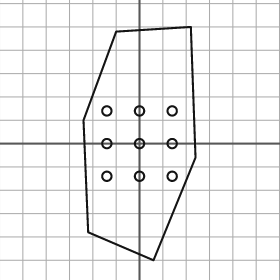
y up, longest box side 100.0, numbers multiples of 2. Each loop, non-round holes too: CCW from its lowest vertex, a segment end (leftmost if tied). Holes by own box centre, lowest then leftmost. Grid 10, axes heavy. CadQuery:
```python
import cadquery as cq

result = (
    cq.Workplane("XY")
    .moveTo(6.0, -50.0)
    .lineTo(24.0, -6.0)
    .lineTo(22.0, 50.0)
    .lineTo(-10.0, 48.0)
    .lineTo(-24.0, 10.0)
    .lineTo(-22.0, -38.0)
    .close()
    .moveTo(-14.0, -14.0)
    .circle(2.0)
    .moveTo(0.0, -14.0)
    .circle(2.0)
    .moveTo(14.0, -14.0)
    .circle(2.0)
    .moveTo(-14.0, 0.0)
    .circle(2.0)
    .moveTo(0.0, 0.0)
    .circle(2.0)
    .moveTo(14.0, 0.0)
    .circle(2.0)
    .moveTo(-14.0, 14.0)
    .circle(2.0)
    .moveTo(0.0, 14.0)
    .circle(2.0)
    .moveTo(14.0, 14.0)
    .circle(2.0)
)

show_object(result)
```